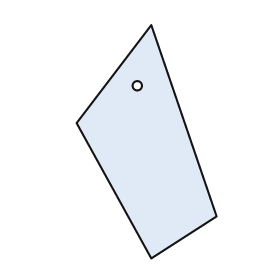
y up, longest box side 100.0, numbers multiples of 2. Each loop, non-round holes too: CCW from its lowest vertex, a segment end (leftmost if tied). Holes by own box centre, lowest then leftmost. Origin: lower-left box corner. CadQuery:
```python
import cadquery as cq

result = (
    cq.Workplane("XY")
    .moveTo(32.0, 0.0)
    .lineTo(60.0, 18.0)
    .lineTo(32.0, 100.0)
    .lineTo(0.0, 58.0)
    .close()
    .moveTo(26.0, 74.0)
    .circle(2.0)
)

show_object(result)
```